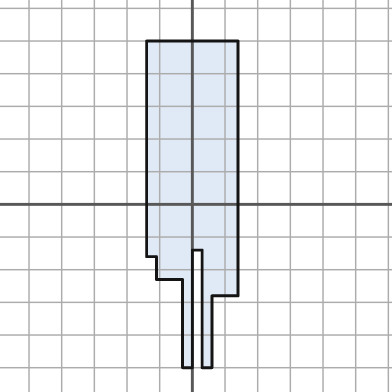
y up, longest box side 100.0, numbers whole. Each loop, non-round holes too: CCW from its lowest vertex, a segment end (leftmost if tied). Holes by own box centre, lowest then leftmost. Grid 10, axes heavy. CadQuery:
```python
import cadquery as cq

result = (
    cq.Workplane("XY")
    .moveTo(-3.0, -50.0)
    .lineTo(0.0, -50.0)
    .lineTo(0.0, -14.0)
    .lineTo(3.0, -14.0)
    .lineTo(3.0, -50.0)
    .lineTo(6.0, -50.0)
    .lineTo(6.0, -28.0)
    .lineTo(14.0, -28.0)
    .lineTo(14.0, 50.0)
    .lineTo(-14.0, 50.0)
    .lineTo(-14.0, -16.0)
    .lineTo(-11.0, -16.0)
    .lineTo(-11.0, -23.0)
    .lineTo(-3.0, -23.0)
    .close()
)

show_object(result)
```